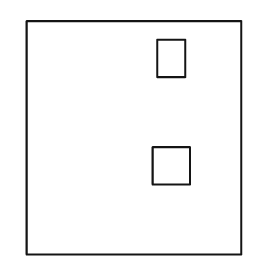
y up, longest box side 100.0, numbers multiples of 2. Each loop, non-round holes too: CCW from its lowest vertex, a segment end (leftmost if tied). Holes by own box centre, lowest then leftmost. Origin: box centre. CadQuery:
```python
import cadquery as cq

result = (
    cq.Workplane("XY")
    .moveTo(-46.0, -50.0)
    .lineTo(46.0, -50.0)
    .lineTo(46.0, 50.0)
    .lineTo(-46.0, 50.0)
    .close()
    .moveTo(8.0, -20.0)
    .lineTo(24.0, -20.0)
    .lineTo(24.0, -4.0)
    .lineTo(8.0, -4.0)
    .close()
    .moveTo(10.0, 26.0)
    .lineTo(22.0, 26.0)
    .lineTo(22.0, 42.0)
    .lineTo(10.0, 42.0)
    .close()
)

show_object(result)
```